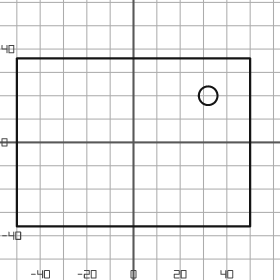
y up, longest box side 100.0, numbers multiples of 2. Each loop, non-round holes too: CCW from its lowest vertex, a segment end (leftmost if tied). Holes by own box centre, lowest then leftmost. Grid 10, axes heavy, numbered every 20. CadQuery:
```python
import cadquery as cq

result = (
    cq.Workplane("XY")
    .moveTo(-50.0, -36.0)
    .lineTo(50.0, -36.0)
    .lineTo(50.0, 36.0)
    .lineTo(-50.0, 36.0)
    .close()
    .moveTo(32.0, 20.0)
    .circle(4.0)
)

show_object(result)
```